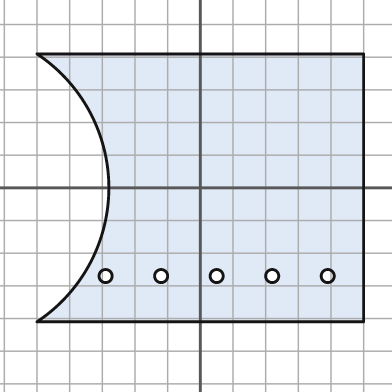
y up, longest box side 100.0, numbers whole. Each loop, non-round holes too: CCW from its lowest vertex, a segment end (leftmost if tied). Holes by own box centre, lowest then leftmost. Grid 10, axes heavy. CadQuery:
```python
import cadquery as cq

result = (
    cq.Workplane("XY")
    .moveTo(-50.0, -41.0)
    .lineTo(50.0, -41.0)
    .lineTo(50.0, 41.0)
    .lineTo(-50.0, 41.0)
    .threePointArc((-28.0, 0.0), (-50.0, -41.0))
    .close()
    .moveTo(-29.0, -27.0)
    .circle(2.0)
    .moveTo(-12.0, -27.0)
    .circle(2.0)
    .moveTo(5.0, -27.0)
    .circle(2.0)
    .moveTo(22.0, -27.0)
    .circle(2.0)
    .moveTo(39.0, -27.0)
    .circle(2.0)
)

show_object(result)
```